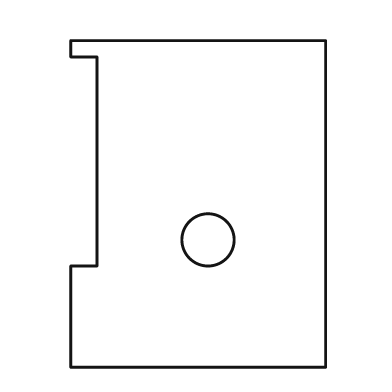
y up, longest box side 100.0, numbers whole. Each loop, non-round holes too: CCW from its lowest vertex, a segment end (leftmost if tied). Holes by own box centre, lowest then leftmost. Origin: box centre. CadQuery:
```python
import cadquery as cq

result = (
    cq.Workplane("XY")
    .moveTo(-39.0, -50.0)
    .lineTo(39.0, -50.0)
    .lineTo(39.0, 50.0)
    .lineTo(-39.0, 50.0)
    .lineTo(-39.0, 45.0)
    .lineTo(-31.0, 45.0)
    .lineTo(-31.0, -19.0)
    .lineTo(-39.0, -19.0)
    .close()
    .moveTo(3.0, -11.0)
    .circle(8.0)
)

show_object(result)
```